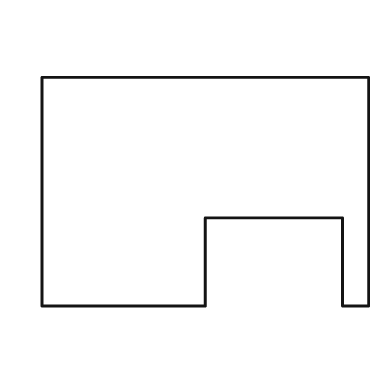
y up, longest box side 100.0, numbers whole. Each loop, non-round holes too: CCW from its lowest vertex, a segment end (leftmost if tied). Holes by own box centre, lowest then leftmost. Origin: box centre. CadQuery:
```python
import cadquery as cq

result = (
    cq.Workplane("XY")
    .moveTo(-50.0, -35.0)
    .lineTo(0.0, -35.0)
    .lineTo(0.0, -8.0)
    .lineTo(42.0, -8.0)
    .lineTo(42.0, -35.0)
    .lineTo(50.0, -35.0)
    .lineTo(50.0, 35.0)
    .lineTo(-50.0, 35.0)
    .close()
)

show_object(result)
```